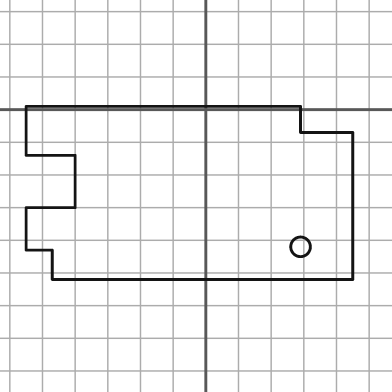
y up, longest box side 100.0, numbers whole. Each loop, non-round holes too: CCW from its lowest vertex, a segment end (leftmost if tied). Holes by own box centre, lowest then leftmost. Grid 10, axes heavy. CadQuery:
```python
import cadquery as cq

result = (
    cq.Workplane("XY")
    .moveTo(-47.0, -52.0)
    .lineTo(45.0, -52.0)
    .lineTo(45.0, -7.0)
    .lineTo(29.0, -7.0)
    .lineTo(29.0, 1.0)
    .lineTo(-55.0, 1.0)
    .lineTo(-55.0, -14.0)
    .lineTo(-40.0, -14.0)
    .lineTo(-40.0, -30.0)
    .lineTo(-55.0, -30.0)
    .lineTo(-55.0, -43.0)
    .lineTo(-47.0, -43.0)
    .close()
    .moveTo(29.0, -42.0)
    .circle(3.0)
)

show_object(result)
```